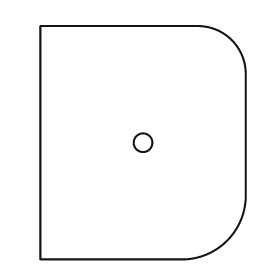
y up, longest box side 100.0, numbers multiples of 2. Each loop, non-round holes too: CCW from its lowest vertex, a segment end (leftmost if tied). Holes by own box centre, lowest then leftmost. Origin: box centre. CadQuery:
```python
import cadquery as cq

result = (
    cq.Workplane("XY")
    .moveTo(-44.0, -50.0)
    .lineTo(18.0, -50.0)
    .threePointArc((36.0, -42.0), (44.0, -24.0))
    .lineTo(44.0, 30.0)
    .threePointArc((38.0, 44.0), (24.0, 50.0))
    .lineTo(-44.0, 50.0)
    .close()
    .moveTo(0.0, 0.0)
    .circle(4.0)
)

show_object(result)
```